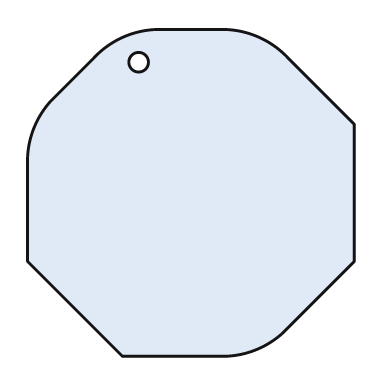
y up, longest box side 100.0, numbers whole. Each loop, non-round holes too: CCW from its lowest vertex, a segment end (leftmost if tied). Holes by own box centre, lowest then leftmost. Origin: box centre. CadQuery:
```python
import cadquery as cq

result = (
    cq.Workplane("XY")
    .moveTo(-21.0, -50.0)
    .lineTo(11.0, -50.0)
    .threePointArc((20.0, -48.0), (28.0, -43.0))
    .lineTo(50.0, -21.0)
    .lineTo(50.0, 21.0)
    .lineTo(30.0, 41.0)
    .threePointArc((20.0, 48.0), (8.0, 50.0))
    .lineTo(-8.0, 50.0)
    .threePointArc((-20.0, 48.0), (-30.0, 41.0))
    .lineTo(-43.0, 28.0)
    .threePointArc((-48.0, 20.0), (-50.0, 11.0))
    .lineTo(-50.0, -21.0)
    .close()
    .moveTo(-16.0, 40.0)
    .circle(3.0)
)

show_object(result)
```